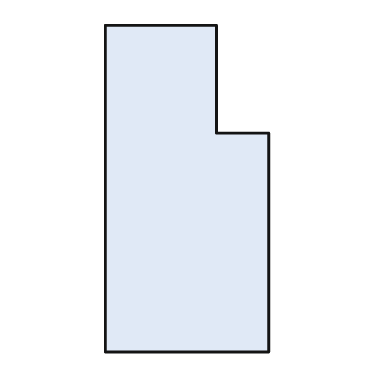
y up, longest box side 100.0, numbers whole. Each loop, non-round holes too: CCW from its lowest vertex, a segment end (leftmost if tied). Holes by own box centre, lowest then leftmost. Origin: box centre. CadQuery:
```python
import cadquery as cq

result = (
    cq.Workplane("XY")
    .moveTo(-25.0, -50.0)
    .lineTo(25.0, -50.0)
    .lineTo(25.0, 17.0)
    .lineTo(9.0, 17.0)
    .lineTo(9.0, 50.0)
    .lineTo(-25.0, 50.0)
    .close()
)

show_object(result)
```